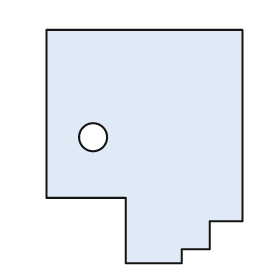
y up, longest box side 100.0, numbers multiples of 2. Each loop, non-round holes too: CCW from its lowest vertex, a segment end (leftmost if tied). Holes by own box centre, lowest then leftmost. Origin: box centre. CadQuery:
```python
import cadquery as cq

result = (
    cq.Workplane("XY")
    .moveTo(-8.0, -50.0)
    .lineTo(16.0, -50.0)
    .lineTo(16.0, -44.0)
    .lineTo(28.0, -44.0)
    .lineTo(28.0, -32.0)
    .lineTo(42.0, -32.0)
    .lineTo(42.0, 50.0)
    .lineTo(-42.0, 50.0)
    .lineTo(-42.0, -22.0)
    .lineTo(-8.0, -22.0)
    .close()
    .moveTo(-22.0, 4.0)
    .circle(6.0)
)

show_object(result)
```